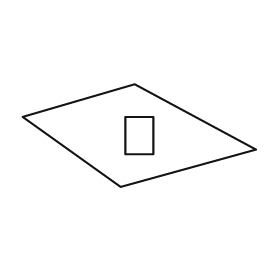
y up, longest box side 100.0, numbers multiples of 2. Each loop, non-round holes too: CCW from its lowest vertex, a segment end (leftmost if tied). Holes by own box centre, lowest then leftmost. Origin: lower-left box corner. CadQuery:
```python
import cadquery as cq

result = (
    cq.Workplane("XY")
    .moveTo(42.0, 0.0)
    .lineTo(100.0, 16.0)
    .lineTo(48.0, 44.0)
    .lineTo(0.0, 30.0)
    .close()
    .moveTo(44.0, 14.0)
    .lineTo(56.0, 14.0)
    .lineTo(56.0, 30.0)
    .lineTo(44.0, 30.0)
    .close()
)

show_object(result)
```